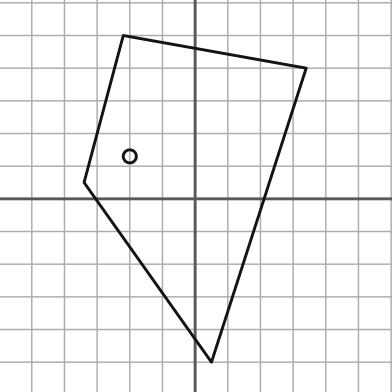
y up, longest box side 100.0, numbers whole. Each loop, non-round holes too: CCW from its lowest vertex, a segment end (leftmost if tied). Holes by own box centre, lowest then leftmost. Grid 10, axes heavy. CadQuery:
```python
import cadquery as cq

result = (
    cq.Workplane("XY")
    .moveTo(5.0, -50.0)
    .lineTo(34.0, 40.0)
    .lineTo(-22.0, 50.0)
    .lineTo(-34.0, 5.0)
    .close()
    .moveTo(-20.0, 13.0)
    .circle(2.0)
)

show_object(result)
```